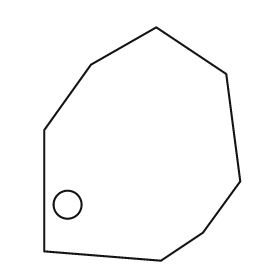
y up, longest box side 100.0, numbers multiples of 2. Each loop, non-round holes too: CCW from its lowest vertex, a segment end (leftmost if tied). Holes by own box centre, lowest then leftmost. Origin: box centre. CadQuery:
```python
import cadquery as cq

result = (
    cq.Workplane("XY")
    .moveTo(8.0, -50.0)
    .lineTo(26.0, -38.0)
    .lineTo(42.0, -16.0)
    .lineTo(36.0, 30.0)
    .lineTo(6.0, 50.0)
    .lineTo(-22.0, 34.0)
    .lineTo(-42.0, 6.0)
    .lineTo(-42.0, -46.0)
    .close()
    .moveTo(-32.0, -26.0)
    .circle(6.0)
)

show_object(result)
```